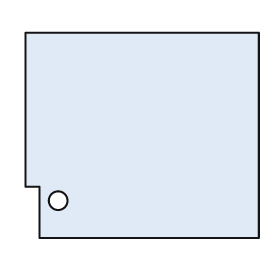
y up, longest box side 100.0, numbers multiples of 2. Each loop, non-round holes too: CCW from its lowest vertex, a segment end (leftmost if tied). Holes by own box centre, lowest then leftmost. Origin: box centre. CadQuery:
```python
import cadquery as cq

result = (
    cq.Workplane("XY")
    .moveTo(-44.0, -44.0)
    .lineTo(50.0, -44.0)
    .lineTo(50.0, 44.0)
    .lineTo(-50.0, 44.0)
    .lineTo(-50.0, -22.0)
    .lineTo(-44.0, -22.0)
    .close()
    .moveTo(-36.0, -28.0)
    .circle(4.0)
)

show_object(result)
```